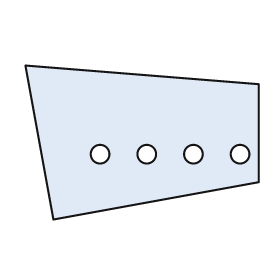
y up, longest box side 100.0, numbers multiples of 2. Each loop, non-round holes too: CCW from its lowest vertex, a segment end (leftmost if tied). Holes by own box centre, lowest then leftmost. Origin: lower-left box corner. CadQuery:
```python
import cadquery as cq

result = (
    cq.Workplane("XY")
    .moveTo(12.0, 0.0)
    .lineTo(100.0, 16.0)
    .lineTo(100.0, 58.0)
    .lineTo(0.0, 66.0)
    .close()
    .moveTo(32.0, 28.0)
    .circle(4.0)
    .moveTo(52.0, 28.0)
    .circle(4.0)
    .moveTo(72.0, 28.0)
    .circle(4.0)
    .moveTo(92.0, 28.0)
    .circle(4.0)
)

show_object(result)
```